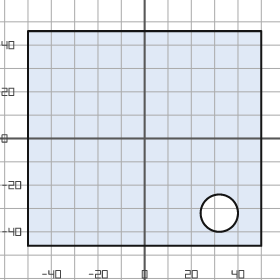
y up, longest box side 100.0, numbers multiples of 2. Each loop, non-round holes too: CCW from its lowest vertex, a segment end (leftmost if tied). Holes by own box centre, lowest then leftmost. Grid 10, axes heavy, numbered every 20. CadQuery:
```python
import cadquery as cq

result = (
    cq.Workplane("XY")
    .moveTo(-50.0, -46.0)
    .lineTo(50.0, -46.0)
    .lineTo(50.0, 46.0)
    .lineTo(-50.0, 46.0)
    .close()
    .moveTo(32.0, -32.0)
    .circle(8.0)
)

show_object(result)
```